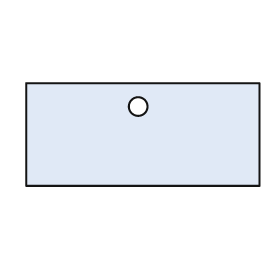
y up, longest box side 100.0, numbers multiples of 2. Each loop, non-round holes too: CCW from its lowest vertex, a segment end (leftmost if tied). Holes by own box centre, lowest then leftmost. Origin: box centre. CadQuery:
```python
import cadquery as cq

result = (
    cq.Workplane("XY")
    .moveTo(-50.0, -22.0)
    .lineTo(50.0, -22.0)
    .lineTo(50.0, 22.0)
    .lineTo(-50.0, 22.0)
    .close()
    .moveTo(-2.0, 12.0)
    .circle(4.0)
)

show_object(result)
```